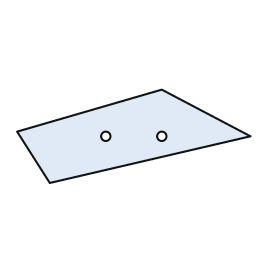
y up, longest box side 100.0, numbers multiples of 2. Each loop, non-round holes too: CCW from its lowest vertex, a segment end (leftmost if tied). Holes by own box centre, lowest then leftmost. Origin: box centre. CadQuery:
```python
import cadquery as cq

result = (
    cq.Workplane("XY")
    .moveTo(-36.0, -20.0)
    .lineTo(50.0, 0.0)
    .lineTo(12.0, 20.0)
    .lineTo(-50.0, 2.0)
    .close()
    .moveTo(-12.0, 0.0)
    .circle(2.0)
    .moveTo(12.0, 0.0)
    .circle(2.0)
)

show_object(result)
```